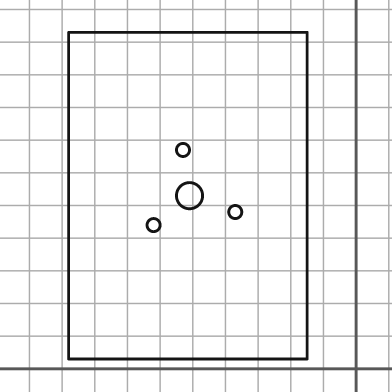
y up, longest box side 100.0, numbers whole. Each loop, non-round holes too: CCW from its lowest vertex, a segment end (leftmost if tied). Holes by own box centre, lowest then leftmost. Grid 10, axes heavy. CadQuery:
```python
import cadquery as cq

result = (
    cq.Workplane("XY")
    .moveTo(-88.0, 3.0)
    .lineTo(-15.0, 3.0)
    .lineTo(-15.0, 103.0)
    .lineTo(-88.0, 103.0)
    .close()
    .moveTo(-62.0, 44.0)
    .circle(2.0)
    .moveTo(-37.0, 48.0)
    .circle(2.0)
    .moveTo(-51.0, 53.0)
    .circle(4.0)
    .moveTo(-53.0, 67.0)
    .circle(2.0)
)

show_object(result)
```